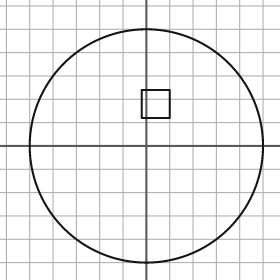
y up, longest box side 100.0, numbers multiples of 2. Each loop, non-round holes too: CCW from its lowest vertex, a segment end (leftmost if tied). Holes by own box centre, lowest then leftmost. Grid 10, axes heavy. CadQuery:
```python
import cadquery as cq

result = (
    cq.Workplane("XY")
    .moveTo(0.0, 0.0)
    .circle(50.0)
    .moveTo(-2.0, 12.0)
    .lineTo(10.0, 12.0)
    .lineTo(10.0, 24.0)
    .lineTo(-2.0, 24.0)
    .close()
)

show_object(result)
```